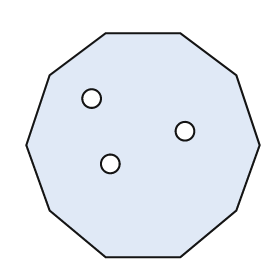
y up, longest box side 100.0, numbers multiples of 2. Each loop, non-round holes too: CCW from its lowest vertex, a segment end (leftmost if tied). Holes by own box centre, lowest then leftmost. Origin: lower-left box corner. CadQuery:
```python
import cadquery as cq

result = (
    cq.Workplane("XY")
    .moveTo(34.0, 0.0)
    .lineTo(66.0, 0.0)
    .lineTo(90.0, 20.0)
    .lineTo(100.0, 48.0)
    .lineTo(90.0, 78.0)
    .lineTo(66.0, 96.0)
    .lineTo(34.0, 96.0)
    .lineTo(10.0, 78.0)
    .lineTo(0.0, 48.0)
    .lineTo(10.0, 20.0)
    .close()
    .moveTo(36.0, 40.0)
    .circle(4.0)
    .moveTo(68.0, 54.0)
    .circle(4.0)
    .moveTo(28.0, 68.0)
    .circle(4.0)
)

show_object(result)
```